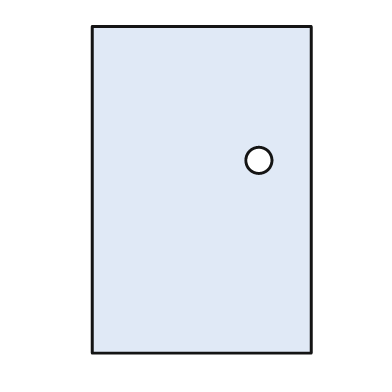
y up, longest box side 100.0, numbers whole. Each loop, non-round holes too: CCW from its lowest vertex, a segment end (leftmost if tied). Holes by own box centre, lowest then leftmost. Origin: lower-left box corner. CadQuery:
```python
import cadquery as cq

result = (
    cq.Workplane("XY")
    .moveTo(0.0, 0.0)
    .lineTo(67.0, 0.0)
    .lineTo(67.0, 100.0)
    .lineTo(0.0, 100.0)
    .close()
    .moveTo(51.0, 59.0)
    .circle(4.0)
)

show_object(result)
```